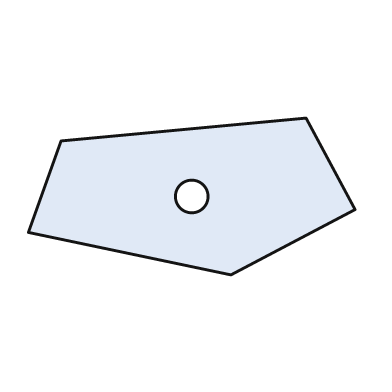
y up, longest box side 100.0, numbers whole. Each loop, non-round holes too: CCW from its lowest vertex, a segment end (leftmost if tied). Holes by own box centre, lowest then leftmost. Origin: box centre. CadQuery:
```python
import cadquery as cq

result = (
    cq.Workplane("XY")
    .moveTo(12.0, -24.0)
    .lineTo(50.0, -4.0)
    .lineTo(35.0, 24.0)
    .lineTo(-40.0, 17.0)
    .lineTo(-50.0, -11.0)
    .close()
    .moveTo(0.0, 0.0)
    .circle(5.0)
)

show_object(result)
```